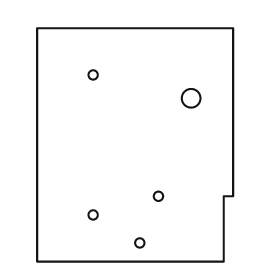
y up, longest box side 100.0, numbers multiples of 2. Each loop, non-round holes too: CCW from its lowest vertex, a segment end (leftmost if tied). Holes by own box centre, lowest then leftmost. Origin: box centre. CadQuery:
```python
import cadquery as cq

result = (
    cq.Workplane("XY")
    .moveTo(-42.0, -50.0)
    .lineTo(38.0, -50.0)
    .lineTo(38.0, -22.0)
    .lineTo(42.0, -22.0)
    .lineTo(42.0, 50.0)
    .lineTo(-42.0, 50.0)
    .close()
    .moveTo(2.0, -42.0)
    .circle(2.0)
    .moveTo(-18.0, -30.0)
    .circle(2.0)
    .moveTo(10.0, -22.0)
    .circle(2.0)
    .moveTo(24.0, 20.0)
    .circle(4.0)
    .moveTo(-18.0, 30.0)
    .circle(2.0)
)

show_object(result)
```